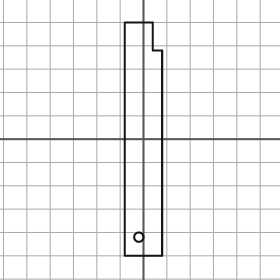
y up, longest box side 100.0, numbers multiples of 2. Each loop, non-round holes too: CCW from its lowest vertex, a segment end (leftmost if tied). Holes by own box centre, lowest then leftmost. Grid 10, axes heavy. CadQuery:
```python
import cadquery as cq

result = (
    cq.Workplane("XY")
    .moveTo(-8.0, -50.0)
    .lineTo(8.0, -50.0)
    .lineTo(8.0, 38.0)
    .lineTo(4.0, 38.0)
    .lineTo(4.0, 50.0)
    .lineTo(-8.0, 50.0)
    .close()
    .moveTo(-2.0, -42.0)
    .circle(2.0)
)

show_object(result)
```